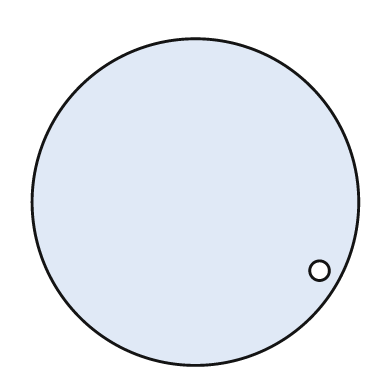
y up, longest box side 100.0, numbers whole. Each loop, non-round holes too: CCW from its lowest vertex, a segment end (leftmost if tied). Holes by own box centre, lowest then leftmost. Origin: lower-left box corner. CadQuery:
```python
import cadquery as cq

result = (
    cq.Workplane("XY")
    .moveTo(50.0, 50.0)
    .circle(50.0)
    .moveTo(88.0, 29.0)
    .circle(3.0)
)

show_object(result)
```